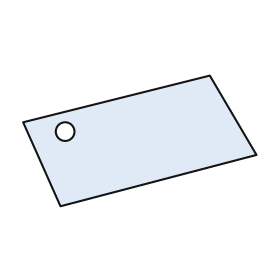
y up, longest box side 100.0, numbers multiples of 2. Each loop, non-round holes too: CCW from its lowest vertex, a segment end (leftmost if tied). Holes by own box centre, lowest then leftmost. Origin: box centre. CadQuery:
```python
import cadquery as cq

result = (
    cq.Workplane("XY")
    .moveTo(-34.0, -28.0)
    .lineTo(50.0, -6.0)
    .lineTo(30.0, 28.0)
    .lineTo(-50.0, 8.0)
    .close()
    .moveTo(-32.0, 4.0)
    .circle(4.0)
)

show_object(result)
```